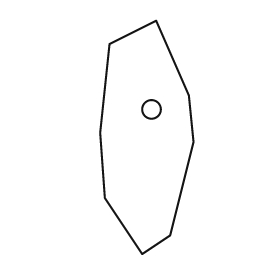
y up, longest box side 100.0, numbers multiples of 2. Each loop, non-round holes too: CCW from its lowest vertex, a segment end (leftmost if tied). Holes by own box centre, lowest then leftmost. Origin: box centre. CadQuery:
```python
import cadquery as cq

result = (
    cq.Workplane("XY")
    .moveTo(-2.0, -50.0)
    .lineTo(10.0, -42.0)
    .lineTo(20.0, -2.0)
    .lineTo(18.0, 18.0)
    .lineTo(4.0, 50.0)
    .lineTo(-16.0, 40.0)
    .lineTo(-20.0, 2.0)
    .lineTo(-18.0, -26.0)
    .close()
    .moveTo(2.0, 12.0)
    .circle(4.0)
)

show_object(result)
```